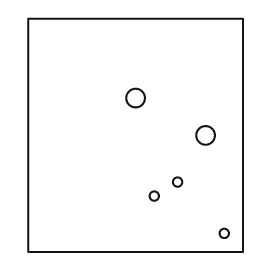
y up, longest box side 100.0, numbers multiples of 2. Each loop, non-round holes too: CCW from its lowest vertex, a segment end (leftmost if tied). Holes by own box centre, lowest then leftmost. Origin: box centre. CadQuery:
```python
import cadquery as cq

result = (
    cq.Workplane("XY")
    .moveTo(-46.0, -50.0)
    .lineTo(46.0, -50.0)
    .lineTo(46.0, 50.0)
    .lineTo(-46.0, 50.0)
    .close()
    .moveTo(38.0, -42.0)
    .circle(2.0)
    .moveTo(8.0, -26.0)
    .circle(2.0)
    .moveTo(18.0, -20.0)
    .circle(2.0)
    .moveTo(30.0, 0.0)
    .circle(4.0)
    .moveTo(0.0, 16.0)
    .circle(4.0)
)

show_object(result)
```